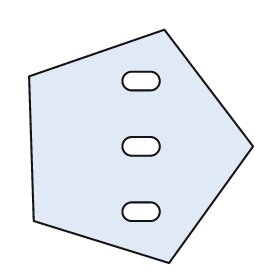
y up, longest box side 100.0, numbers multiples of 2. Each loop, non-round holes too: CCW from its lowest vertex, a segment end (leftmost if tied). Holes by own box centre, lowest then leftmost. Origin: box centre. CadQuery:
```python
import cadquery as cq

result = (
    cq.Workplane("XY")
    .moveTo(12.0, -50.0)
    .lineTo(48.0, 0.0)
    .lineTo(10.0, 50.0)
    .lineTo(-48.0, 30.0)
    .lineTo(-46.0, -32.0)
    .close()
    .moveTo(-4.0, -32.0)
    .lineTo(4.0, -32.0)
    .threePointArc((8.0, -28.0), (4.0, -24.0))
    .lineTo(-4.0, -24.0)
    .threePointArc((-8.0, -28.0), (-4.0, -32.0))
    .close()
    .moveTo(-4.0, -4.0)
    .lineTo(4.0, -4.0)
    .threePointArc((8.0, 0.0), (4.0, 4.0))
    .lineTo(-4.0, 4.0)
    .threePointArc((-8.0, 0.0), (-4.0, -4.0))
    .close()
    .moveTo(-4.0, 24.0)
    .lineTo(4.0, 24.0)
    .threePointArc((8.0, 28.0), (4.0, 32.0))
    .lineTo(-4.0, 32.0)
    .threePointArc((-8.0, 28.0), (-4.0, 24.0))
    .close()
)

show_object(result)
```